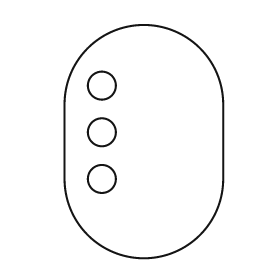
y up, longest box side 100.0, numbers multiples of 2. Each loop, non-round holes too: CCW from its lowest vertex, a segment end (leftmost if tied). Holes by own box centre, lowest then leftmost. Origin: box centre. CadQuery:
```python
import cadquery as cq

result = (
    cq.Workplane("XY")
    .moveTo(-34.0, -16.0)
    .threePointArc((0.0, -50.0), (34.0, -16.0))
    .lineTo(34.0, 16.0)
    .threePointArc((0.0, 50.0), (-34.0, 16.0))
    .close()
    .moveTo(-18.0, -16.0)
    .circle(6.0)
    .moveTo(-18.0, 4.0)
    .circle(6.0)
    .moveTo(-18.0, 24.0)
    .circle(6.0)
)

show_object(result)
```